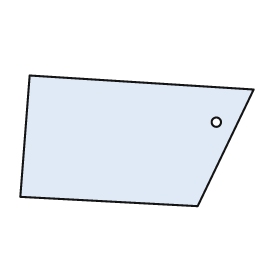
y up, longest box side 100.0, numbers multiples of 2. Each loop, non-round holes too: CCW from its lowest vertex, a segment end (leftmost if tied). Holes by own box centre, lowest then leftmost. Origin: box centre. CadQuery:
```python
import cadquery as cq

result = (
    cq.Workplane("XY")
    .moveTo(26.0, -28.0)
    .lineTo(50.0, 22.0)
    .lineTo(-46.0, 28.0)
    .lineTo(-50.0, -24.0)
    .close()
    .moveTo(34.0, 8.0)
    .circle(2.0)
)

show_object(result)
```